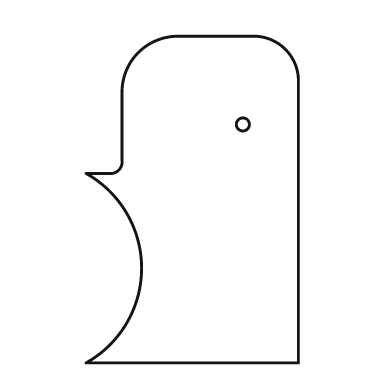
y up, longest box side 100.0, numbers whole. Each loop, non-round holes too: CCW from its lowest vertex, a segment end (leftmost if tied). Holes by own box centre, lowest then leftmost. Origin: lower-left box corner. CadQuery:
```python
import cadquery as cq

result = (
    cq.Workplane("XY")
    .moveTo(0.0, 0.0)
    .lineTo(65.0, 0.0)
    .lineTo(65.0, 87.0)
    .threePointArc((61.0, 96.0), (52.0, 100.0))
    .lineTo(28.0, 100.0)
    .threePointArc((16.0, 95.0), (11.0, 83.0))
    .lineTo(11.0, 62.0)
    .threePointArc((10.0, 59.0), (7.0, 58.0))
    .lineTo(0.0, 58.0)
    .threePointArc((17.0, 29.0), (0.0, 0.0))
    .close()
    .moveTo(48.0, 73.0)
    .circle(2.0)
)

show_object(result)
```